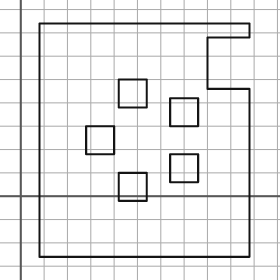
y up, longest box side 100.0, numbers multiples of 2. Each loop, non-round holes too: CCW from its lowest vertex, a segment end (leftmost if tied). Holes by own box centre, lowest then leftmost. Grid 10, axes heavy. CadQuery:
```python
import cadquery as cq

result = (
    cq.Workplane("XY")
    .moveTo(8.0, -26.0)
    .lineTo(98.0, -26.0)
    .lineTo(98.0, 46.0)
    .lineTo(80.0, 46.0)
    .lineTo(80.0, 68.0)
    .lineTo(98.0, 68.0)
    .lineTo(98.0, 74.0)
    .lineTo(8.0, 74.0)
    .close()
    .moveTo(42.0, -2.0)
    .lineTo(54.0, -2.0)
    .lineTo(54.0, 10.0)
    .lineTo(42.0, 10.0)
    .close()
    .moveTo(64.0, 6.0)
    .lineTo(76.0, 6.0)
    .lineTo(76.0, 18.0)
    .lineTo(64.0, 18.0)
    .close()
    .moveTo(28.0, 18.0)
    .lineTo(40.0, 18.0)
    .lineTo(40.0, 30.0)
    .lineTo(28.0, 30.0)
    .close()
    .moveTo(64.0, 30.0)
    .lineTo(76.0, 30.0)
    .lineTo(76.0, 42.0)
    .lineTo(64.0, 42.0)
    .close()
    .moveTo(42.0, 38.0)
    .lineTo(54.0, 38.0)
    .lineTo(54.0, 50.0)
    .lineTo(42.0, 50.0)
    .close()
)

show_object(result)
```